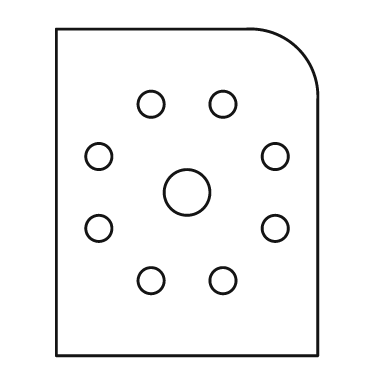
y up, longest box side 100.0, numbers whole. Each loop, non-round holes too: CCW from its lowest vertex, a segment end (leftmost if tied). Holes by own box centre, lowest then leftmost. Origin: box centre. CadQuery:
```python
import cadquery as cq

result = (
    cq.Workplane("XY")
    .moveTo(-40.0, -50.0)
    .lineTo(40.0, -50.0)
    .lineTo(40.0, 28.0)
    .threePointArc((34.0, 44.0), (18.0, 50.0))
    .lineTo(-40.0, 50.0)
    .close()
    .moveTo(-11.0, -27.0)
    .circle(4.0)
    .moveTo(11.0, -27.0)
    .circle(4.0)
    .moveTo(-27.0, -11.0)
    .circle(4.0)
    .moveTo(27.0, -11.0)
    .circle(4.0)
    .moveTo(0.0, 0.0)
    .circle(7.0)
    .moveTo(-27.0, 11.0)
    .circle(4.0)
    .moveTo(27.0, 11.0)
    .circle(4.0)
    .moveTo(-11.0, 27.0)
    .circle(4.0)
    .moveTo(11.0, 27.0)
    .circle(4.0)
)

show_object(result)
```